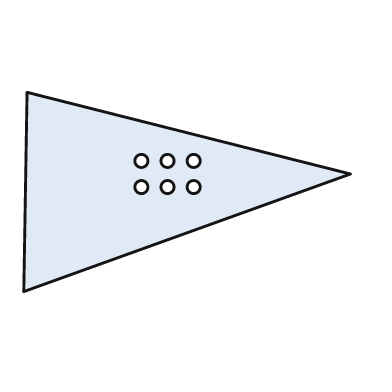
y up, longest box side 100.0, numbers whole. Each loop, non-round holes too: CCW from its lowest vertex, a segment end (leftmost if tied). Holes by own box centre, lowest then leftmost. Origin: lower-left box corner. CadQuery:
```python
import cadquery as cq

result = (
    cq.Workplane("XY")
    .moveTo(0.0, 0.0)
    .lineTo(100.0, 36.0)
    .lineTo(1.0, 61.0)
    .close()
    .moveTo(36.0, 32.0)
    .circle(2.0)
    .moveTo(44.0, 32.0)
    .circle(2.0)
    .moveTo(52.0, 32.0)
    .circle(2.0)
    .moveTo(36.0, 40.0)
    .circle(2.0)
    .moveTo(44.0, 40.0)
    .circle(2.0)
    .moveTo(52.0, 40.0)
    .circle(2.0)
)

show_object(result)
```